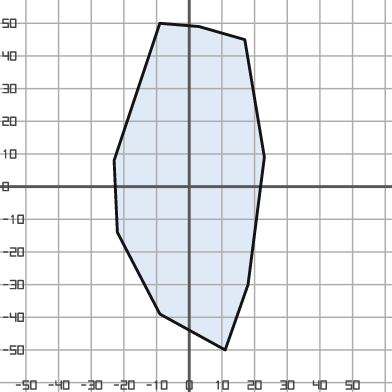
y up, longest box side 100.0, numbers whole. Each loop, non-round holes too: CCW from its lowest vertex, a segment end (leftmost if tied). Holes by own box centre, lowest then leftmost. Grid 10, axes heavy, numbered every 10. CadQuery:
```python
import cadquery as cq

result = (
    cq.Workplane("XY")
    .moveTo(11.0, -50.0)
    .lineTo(18.0, -30.0)
    .lineTo(23.0, 9.0)
    .lineTo(17.0, 45.0)
    .lineTo(3.0, 49.0)
    .lineTo(-9.0, 50.0)
    .lineTo(-23.0, 8.0)
    .lineTo(-22.0, -14.0)
    .lineTo(-9.0, -39.0)
    .close()
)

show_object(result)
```